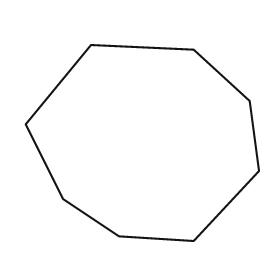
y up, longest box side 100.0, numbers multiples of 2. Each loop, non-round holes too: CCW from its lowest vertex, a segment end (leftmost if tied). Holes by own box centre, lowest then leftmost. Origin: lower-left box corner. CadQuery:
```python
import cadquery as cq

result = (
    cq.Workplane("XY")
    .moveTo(72.0, 0.0)
    .lineTo(100.0, 30.0)
    .lineTo(96.0, 60.0)
    .lineTo(72.0, 82.0)
    .lineTo(28.0, 84.0)
    .lineTo(0.0, 50.0)
    .lineTo(16.0, 18.0)
    .lineTo(40.0, 2.0)
    .close()
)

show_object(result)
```